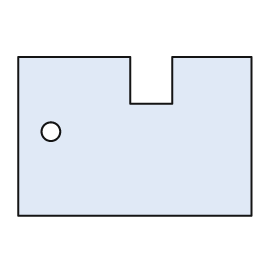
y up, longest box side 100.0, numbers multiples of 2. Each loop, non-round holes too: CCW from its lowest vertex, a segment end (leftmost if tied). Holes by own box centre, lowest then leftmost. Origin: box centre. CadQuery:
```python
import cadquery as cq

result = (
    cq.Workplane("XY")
    .moveTo(-50.0, -34.0)
    .lineTo(50.0, -34.0)
    .lineTo(50.0, 34.0)
    .lineTo(16.0, 34.0)
    .lineTo(16.0, 14.0)
    .lineTo(-2.0, 14.0)
    .lineTo(-2.0, 34.0)
    .lineTo(-50.0, 34.0)
    .close()
    .moveTo(-36.0, 2.0)
    .circle(4.0)
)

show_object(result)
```